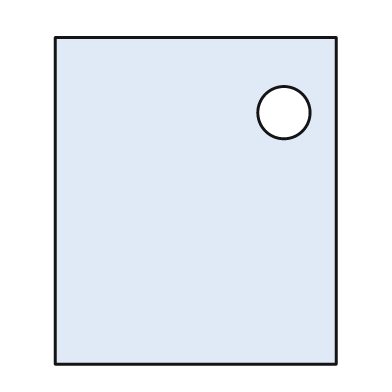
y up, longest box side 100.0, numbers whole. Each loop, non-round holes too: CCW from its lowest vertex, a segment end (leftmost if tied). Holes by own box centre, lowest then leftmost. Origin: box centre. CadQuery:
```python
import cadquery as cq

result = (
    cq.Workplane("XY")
    .moveTo(-43.0, -50.0)
    .lineTo(43.0, -50.0)
    .lineTo(43.0, 50.0)
    .lineTo(-43.0, 50.0)
    .close()
    .moveTo(27.0, 27.0)
    .circle(8.0)
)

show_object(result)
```